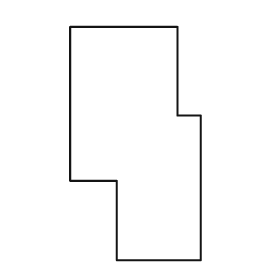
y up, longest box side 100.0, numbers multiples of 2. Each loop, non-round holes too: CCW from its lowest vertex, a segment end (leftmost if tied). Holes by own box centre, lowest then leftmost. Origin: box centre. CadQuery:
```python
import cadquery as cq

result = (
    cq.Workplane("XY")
    .moveTo(-8.0, -50.0)
    .lineTo(28.0, -50.0)
    .lineTo(28.0, 12.0)
    .lineTo(18.0, 12.0)
    .lineTo(18.0, 50.0)
    .lineTo(-28.0, 50.0)
    .lineTo(-28.0, -16.0)
    .lineTo(-8.0, -16.0)
    .close()
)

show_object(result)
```